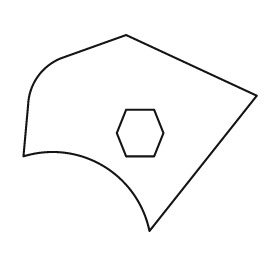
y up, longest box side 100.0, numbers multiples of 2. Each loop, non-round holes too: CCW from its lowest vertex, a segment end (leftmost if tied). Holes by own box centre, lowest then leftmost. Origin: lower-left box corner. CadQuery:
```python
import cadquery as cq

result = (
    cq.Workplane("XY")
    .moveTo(54.0, 0.0)
    .lineTo(100.0, 58.0)
    .lineTo(44.0, 84.0)
    .lineTo(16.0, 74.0)
    .threePointArc((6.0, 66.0), (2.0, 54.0))
    .lineTo(0.0, 32.0)
    .threePointArc((34.0, 28.0), (54.0, 0.0))
    .close()
    .moveTo(44.0, 32.0)
    .lineTo(56.0, 32.0)
    .lineTo(60.0, 42.0)
    .lineTo(56.0, 52.0)
    .lineTo(44.0, 52.0)
    .lineTo(40.0, 42.0)
    .close()
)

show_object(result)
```